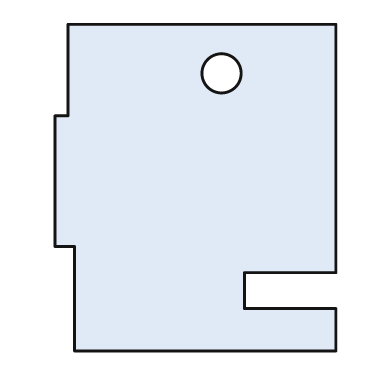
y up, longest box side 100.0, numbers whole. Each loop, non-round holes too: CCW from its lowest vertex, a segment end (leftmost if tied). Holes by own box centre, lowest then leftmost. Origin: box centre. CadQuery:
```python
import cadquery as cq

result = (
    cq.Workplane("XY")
    .moveTo(-37.0, -50.0)
    .lineTo(43.0, -50.0)
    .lineTo(43.0, -37.0)
    .lineTo(15.0, -37.0)
    .lineTo(15.0, -26.0)
    .lineTo(43.0, -26.0)
    .lineTo(43.0, 50.0)
    .lineTo(-39.0, 50.0)
    .lineTo(-39.0, 22.0)
    .lineTo(-43.0, 22.0)
    .lineTo(-43.0, -18.0)
    .lineTo(-37.0, -18.0)
    .close()
    .moveTo(8.0, 35.0)
    .circle(6.0)
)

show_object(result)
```